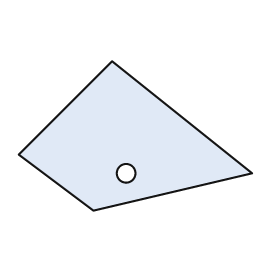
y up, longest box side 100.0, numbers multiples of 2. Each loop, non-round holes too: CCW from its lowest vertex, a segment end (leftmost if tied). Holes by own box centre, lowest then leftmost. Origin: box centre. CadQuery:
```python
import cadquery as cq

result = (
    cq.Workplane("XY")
    .moveTo(-18.0, -32.0)
    .lineTo(50.0, -16.0)
    .lineTo(-10.0, 32.0)
    .lineTo(-50.0, -8.0)
    .close()
    .moveTo(-4.0, -16.0)
    .circle(4.0)
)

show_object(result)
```